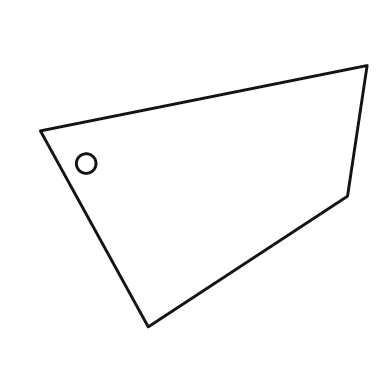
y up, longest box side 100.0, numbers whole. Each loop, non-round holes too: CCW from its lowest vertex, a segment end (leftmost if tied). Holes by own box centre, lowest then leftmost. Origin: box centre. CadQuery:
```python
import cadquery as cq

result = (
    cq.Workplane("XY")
    .moveTo(-17.0, -40.0)
    .lineTo(44.0, 0.0)
    .lineTo(50.0, 40.0)
    .lineTo(-50.0, 20.0)
    .close()
    .moveTo(-36.0, 10.0)
    .circle(3.0)
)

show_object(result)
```